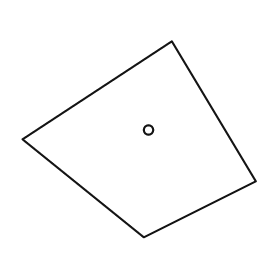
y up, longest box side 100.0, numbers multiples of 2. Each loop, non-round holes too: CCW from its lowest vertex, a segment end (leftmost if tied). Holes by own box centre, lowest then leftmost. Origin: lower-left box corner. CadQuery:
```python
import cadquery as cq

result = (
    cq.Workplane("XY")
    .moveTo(52.0, 0.0)
    .lineTo(100.0, 24.0)
    .lineTo(64.0, 84.0)
    .lineTo(0.0, 42.0)
    .close()
    .moveTo(54.0, 46.0)
    .circle(2.0)
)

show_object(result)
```